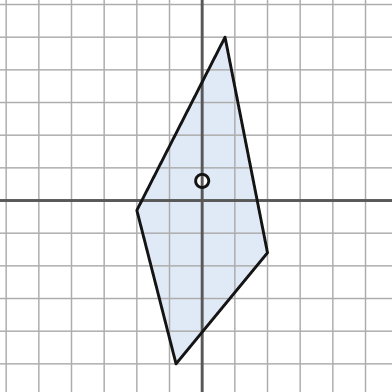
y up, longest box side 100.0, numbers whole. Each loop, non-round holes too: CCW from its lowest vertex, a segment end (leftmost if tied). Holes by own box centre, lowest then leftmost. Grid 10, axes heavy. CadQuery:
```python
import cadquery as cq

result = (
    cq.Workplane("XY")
    .moveTo(-8.0, -50.0)
    .lineTo(20.0, -16.0)
    .lineTo(7.0, 50.0)
    .lineTo(-20.0, -3.0)
    .close()
    .moveTo(0.0, 6.0)
    .circle(2.0)
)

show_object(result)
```